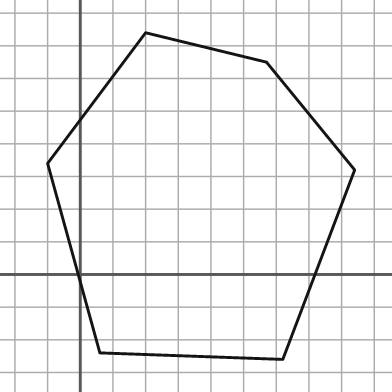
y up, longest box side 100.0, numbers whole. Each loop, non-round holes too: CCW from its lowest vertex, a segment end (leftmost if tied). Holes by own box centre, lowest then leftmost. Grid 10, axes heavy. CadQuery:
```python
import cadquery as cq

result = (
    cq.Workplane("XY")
    .moveTo(62.0, -26.0)
    .lineTo(84.0, 32.0)
    .lineTo(57.0, 65.0)
    .lineTo(20.0, 74.0)
    .lineTo(-10.0, 34.0)
    .lineTo(6.0, -24.0)
    .close()
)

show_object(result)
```